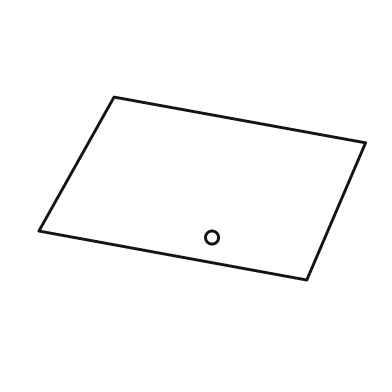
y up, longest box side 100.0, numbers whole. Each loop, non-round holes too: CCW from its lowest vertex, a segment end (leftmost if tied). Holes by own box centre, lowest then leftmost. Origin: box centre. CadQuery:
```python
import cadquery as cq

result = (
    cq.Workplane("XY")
    .moveTo(32.0, -28.0)
    .lineTo(50.0, 14.0)
    .lineTo(-27.0, 28.0)
    .lineTo(-50.0, -13.0)
    .close()
    .moveTo(3.0, -15.0)
    .circle(2.0)
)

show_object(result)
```